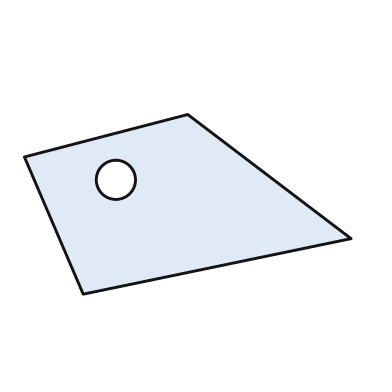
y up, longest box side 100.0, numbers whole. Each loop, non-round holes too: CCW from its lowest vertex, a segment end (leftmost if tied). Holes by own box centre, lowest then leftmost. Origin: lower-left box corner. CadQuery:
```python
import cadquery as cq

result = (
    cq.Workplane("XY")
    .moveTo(18.0, 0.0)
    .lineTo(100.0, 17.0)
    .lineTo(50.0, 55.0)
    .lineTo(0.0, 42.0)
    .close()
    .moveTo(28.0, 35.0)
    .circle(6.0)
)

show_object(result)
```